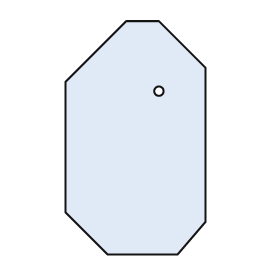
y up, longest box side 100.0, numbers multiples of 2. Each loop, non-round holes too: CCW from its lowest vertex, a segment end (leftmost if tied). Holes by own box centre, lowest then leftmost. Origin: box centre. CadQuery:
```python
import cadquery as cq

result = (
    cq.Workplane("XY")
    .moveTo(-12.0, -50.0)
    .lineTo(18.0, -50.0)
    .lineTo(30.0, -36.0)
    .lineTo(30.0, 30.0)
    .lineTo(10.0, 50.0)
    .lineTo(-4.0, 50.0)
    .lineTo(-30.0, 24.0)
    .lineTo(-30.0, -32.0)
    .close()
    .moveTo(10.0, 20.0)
    .circle(2.0)
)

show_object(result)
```